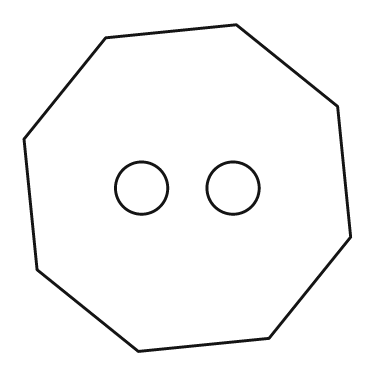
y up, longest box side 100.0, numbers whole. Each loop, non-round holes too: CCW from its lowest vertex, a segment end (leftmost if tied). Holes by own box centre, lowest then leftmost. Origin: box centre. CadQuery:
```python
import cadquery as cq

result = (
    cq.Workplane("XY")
    .moveTo(-15.0, -50.0)
    .lineTo(25.0, -46.0)
    .lineTo(50.0, -15.0)
    .lineTo(46.0, 25.0)
    .lineTo(15.0, 50.0)
    .lineTo(-25.0, 46.0)
    .lineTo(-50.0, 15.0)
    .lineTo(-46.0, -25.0)
    .close()
    .moveTo(-14.0, 0.0)
    .circle(8.0)
    .moveTo(14.0, 0.0)
    .circle(8.0)
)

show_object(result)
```